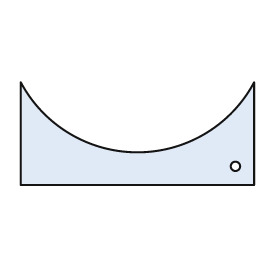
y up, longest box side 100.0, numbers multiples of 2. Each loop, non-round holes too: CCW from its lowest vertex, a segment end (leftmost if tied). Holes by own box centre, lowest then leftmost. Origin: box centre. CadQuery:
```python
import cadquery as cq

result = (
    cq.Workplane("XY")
    .moveTo(-50.0, -22.0)
    .lineTo(50.0, -22.0)
    .lineTo(50.0, 22.0)
    .threePointArc((0.0, -8.0), (-50.0, 22.0))
    .close()
    .moveTo(42.0, -14.0)
    .circle(2.0)
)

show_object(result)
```